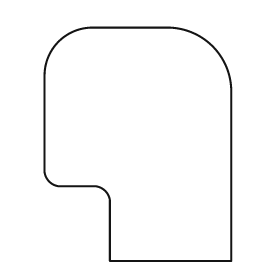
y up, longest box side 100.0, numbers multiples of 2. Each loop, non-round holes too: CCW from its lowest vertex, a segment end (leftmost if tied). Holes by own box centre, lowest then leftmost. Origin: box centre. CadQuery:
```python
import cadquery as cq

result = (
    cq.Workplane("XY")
    .moveTo(-12.0, -50.0)
    .lineTo(40.0, -50.0)
    .lineTo(40.0, 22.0)
    .threePointArc((32.0, 42.0), (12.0, 50.0))
    .lineTo(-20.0, 50.0)
    .threePointArc((-34.0, 44.0), (-40.0, 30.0))
    .lineTo(-40.0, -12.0)
    .threePointArc((-38.0, -16.0), (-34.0, -18.0))
    .lineTo(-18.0, -18.0)
    .threePointArc((-14.0, -20.0), (-12.0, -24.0))
    .close()
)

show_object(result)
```